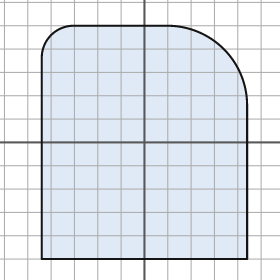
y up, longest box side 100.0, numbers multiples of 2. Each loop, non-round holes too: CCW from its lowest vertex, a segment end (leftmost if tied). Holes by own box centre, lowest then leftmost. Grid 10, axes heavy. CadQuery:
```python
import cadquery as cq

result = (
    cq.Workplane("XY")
    .moveTo(-44.0, -50.0)
    .lineTo(44.0, -50.0)
    .lineTo(44.0, 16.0)
    .threePointArc((34.0, 40.0), (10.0, 50.0))
    .lineTo(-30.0, 50.0)
    .threePointArc((-40.0, 46.0), (-44.0, 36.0))
    .close()
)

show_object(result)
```